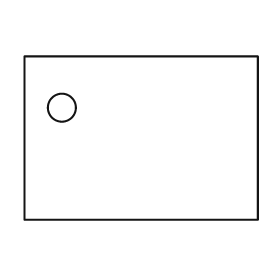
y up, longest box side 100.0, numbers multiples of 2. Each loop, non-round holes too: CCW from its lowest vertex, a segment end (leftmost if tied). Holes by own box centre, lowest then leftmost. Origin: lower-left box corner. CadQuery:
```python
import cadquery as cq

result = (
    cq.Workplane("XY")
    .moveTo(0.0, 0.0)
    .lineTo(100.0, 0.0)
    .lineTo(100.0, 70.0)
    .lineTo(0.0, 70.0)
    .close()
    .moveTo(16.0, 48.0)
    .circle(6.0)
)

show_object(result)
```